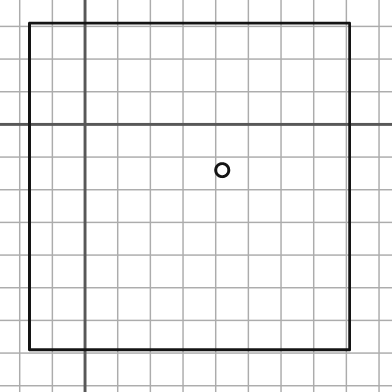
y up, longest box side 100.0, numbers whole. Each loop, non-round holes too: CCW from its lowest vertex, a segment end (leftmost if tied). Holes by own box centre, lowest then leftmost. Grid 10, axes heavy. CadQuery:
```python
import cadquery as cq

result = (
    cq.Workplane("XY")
    .moveTo(-17.0, -69.0)
    .lineTo(81.0, -69.0)
    .lineTo(81.0, 31.0)
    .lineTo(-17.0, 31.0)
    .close()
    .moveTo(42.0, -14.0)
    .circle(2.0)
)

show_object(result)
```